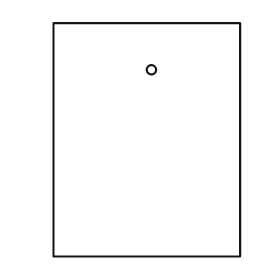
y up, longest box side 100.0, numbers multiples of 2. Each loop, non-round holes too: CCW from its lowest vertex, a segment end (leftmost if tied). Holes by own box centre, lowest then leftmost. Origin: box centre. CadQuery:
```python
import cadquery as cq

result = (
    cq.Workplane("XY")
    .moveTo(-40.0, -50.0)
    .lineTo(40.0, -50.0)
    .lineTo(40.0, 50.0)
    .lineTo(-40.0, 50.0)
    .close()
    .moveTo(2.0, 30.0)
    .circle(2.0)
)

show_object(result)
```